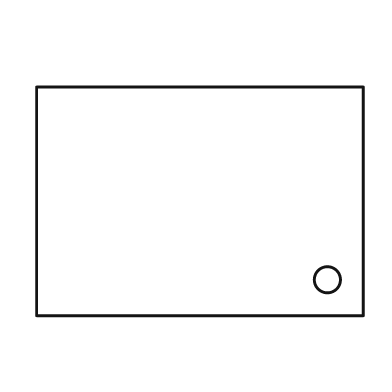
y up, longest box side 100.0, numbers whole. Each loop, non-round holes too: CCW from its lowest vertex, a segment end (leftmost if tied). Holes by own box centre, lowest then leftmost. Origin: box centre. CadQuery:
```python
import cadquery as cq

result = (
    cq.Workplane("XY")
    .moveTo(-50.0, -35.0)
    .lineTo(50.0, -35.0)
    .lineTo(50.0, 35.0)
    .lineTo(-50.0, 35.0)
    .close()
    .moveTo(39.0, -24.0)
    .circle(4.0)
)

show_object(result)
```